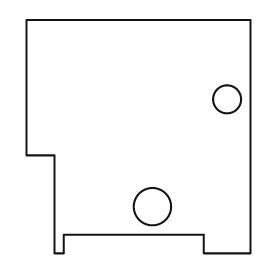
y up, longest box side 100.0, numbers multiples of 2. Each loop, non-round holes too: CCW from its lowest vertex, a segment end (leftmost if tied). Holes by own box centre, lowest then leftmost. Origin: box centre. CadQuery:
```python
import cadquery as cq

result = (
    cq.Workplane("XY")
    .moveTo(-36.0, -50.0)
    .lineTo(-32.0, -50.0)
    .lineTo(-32.0, -42.0)
    .lineTo(28.0, -42.0)
    .lineTo(28.0, -50.0)
    .lineTo(48.0, -50.0)
    .lineTo(48.0, 50.0)
    .lineTo(-48.0, 50.0)
    .lineTo(-48.0, -8.0)
    .lineTo(-36.0, -8.0)
    .close()
    .moveTo(6.0, -30.0)
    .circle(8.0)
    .moveTo(38.0, 16.0)
    .circle(6.0)
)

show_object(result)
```